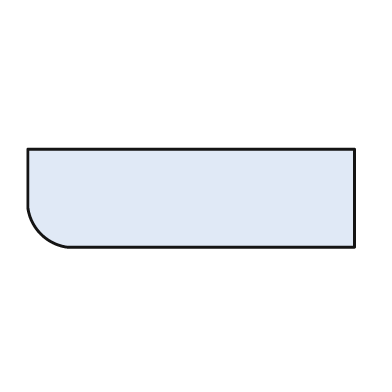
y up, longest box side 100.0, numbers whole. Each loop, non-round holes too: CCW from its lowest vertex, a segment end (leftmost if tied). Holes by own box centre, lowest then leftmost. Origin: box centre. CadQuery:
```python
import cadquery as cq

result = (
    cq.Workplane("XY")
    .moveTo(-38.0, -15.0)
    .lineTo(50.0, -15.0)
    .lineTo(50.0, 15.0)
    .lineTo(-50.0, 15.0)
    .lineTo(-50.0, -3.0)
    .threePointArc((-46.0, -11.0), (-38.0, -15.0))
    .close()
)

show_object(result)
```